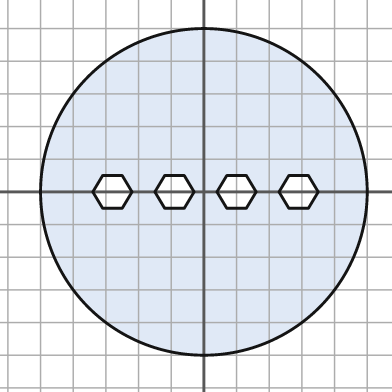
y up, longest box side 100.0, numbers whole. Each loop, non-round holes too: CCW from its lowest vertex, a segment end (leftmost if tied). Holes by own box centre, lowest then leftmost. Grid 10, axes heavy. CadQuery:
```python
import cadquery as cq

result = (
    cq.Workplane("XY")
    .moveTo(0.0, 0.0)
    .circle(50.0)
    .moveTo(-31.0, -5.0)
    .lineTo(-25.0, -5.0)
    .lineTo(-22.0, 0.0)
    .lineTo(-25.0, 5.0)
    .lineTo(-31.0, 5.0)
    .lineTo(-34.0, 0.0)
    .close()
    .moveTo(-12.0, -5.0)
    .lineTo(-6.0, -5.0)
    .lineTo(-3.0, 0.0)
    .lineTo(-6.0, 5.0)
    .lineTo(-12.0, 5.0)
    .lineTo(-15.0, 0.0)
    .close()
    .moveTo(7.0, -5.0)
    .lineTo(13.0, -5.0)
    .lineTo(16.0, 0.0)
    .lineTo(13.0, 5.0)
    .lineTo(7.0, 5.0)
    .lineTo(4.0, 0.0)
    .close()
    .moveTo(26.0, -5.0)
    .lineTo(32.0, -5.0)
    .lineTo(35.0, 0.0)
    .lineTo(32.0, 5.0)
    .lineTo(26.0, 5.0)
    .lineTo(23.0, 0.0)
    .close()
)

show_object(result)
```